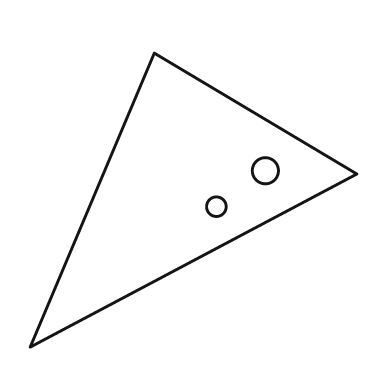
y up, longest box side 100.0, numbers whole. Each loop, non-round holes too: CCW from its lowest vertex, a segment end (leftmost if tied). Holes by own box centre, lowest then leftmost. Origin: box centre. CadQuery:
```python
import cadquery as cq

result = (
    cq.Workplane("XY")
    .moveTo(-50.0, -45.0)
    .lineTo(50.0, 8.0)
    .lineTo(-12.0, 45.0)
    .close()
    .moveTo(7.0, -2.0)
    .circle(3.0)
    .moveTo(22.0, 9.0)
    .circle(4.0)
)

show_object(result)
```